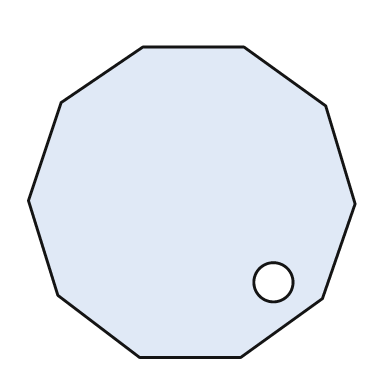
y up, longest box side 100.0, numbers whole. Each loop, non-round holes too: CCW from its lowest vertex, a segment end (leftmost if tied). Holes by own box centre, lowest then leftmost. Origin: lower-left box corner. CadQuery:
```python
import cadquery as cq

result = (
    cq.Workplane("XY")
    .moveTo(34.0, 0.0)
    .lineTo(65.0, 0.0)
    .lineTo(90.0, 18.0)
    .lineTo(100.0, 47.0)
    .lineTo(91.0, 77.0)
    .lineTo(66.0, 95.0)
    .lineTo(35.0, 95.0)
    .lineTo(10.0, 78.0)
    .lineTo(0.0, 48.0)
    .lineTo(9.0, 19.0)
    .close()
    .moveTo(75.0, 23.0)
    .circle(6.0)
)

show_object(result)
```